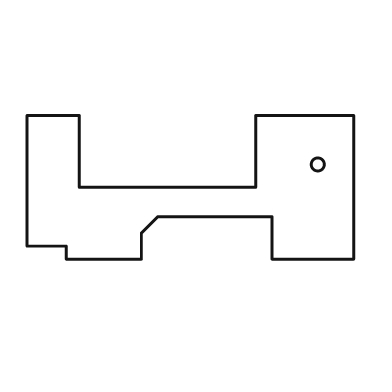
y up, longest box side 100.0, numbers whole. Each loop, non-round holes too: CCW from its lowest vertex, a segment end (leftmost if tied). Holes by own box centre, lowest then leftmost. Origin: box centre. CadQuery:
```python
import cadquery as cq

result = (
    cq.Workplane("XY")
    .moveTo(-38.0, -22.0)
    .lineTo(-15.0, -22.0)
    .lineTo(-15.0, -14.0)
    .lineTo(-10.0, -9.0)
    .lineTo(25.0, -9.0)
    .lineTo(25.0, -22.0)
    .lineTo(50.0, -22.0)
    .lineTo(50.0, 22.0)
    .lineTo(20.0, 22.0)
    .lineTo(20.0, 0.0)
    .lineTo(-34.0, 0.0)
    .lineTo(-34.0, 22.0)
    .lineTo(-50.0, 22.0)
    .lineTo(-50.0, -18.0)
    .lineTo(-38.0, -18.0)
    .close()
    .moveTo(39.0, 7.0)
    .circle(2.0)
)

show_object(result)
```